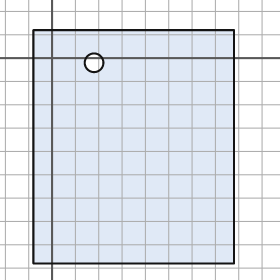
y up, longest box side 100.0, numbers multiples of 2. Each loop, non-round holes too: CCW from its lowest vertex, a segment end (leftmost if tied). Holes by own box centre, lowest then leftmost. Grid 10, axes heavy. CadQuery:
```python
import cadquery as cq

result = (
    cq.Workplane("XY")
    .moveTo(-8.0, -88.0)
    .lineTo(78.0, -88.0)
    .lineTo(78.0, 12.0)
    .lineTo(-8.0, 12.0)
    .close()
    .moveTo(18.0, -2.0)
    .circle(4.0)
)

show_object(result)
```